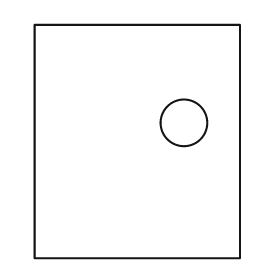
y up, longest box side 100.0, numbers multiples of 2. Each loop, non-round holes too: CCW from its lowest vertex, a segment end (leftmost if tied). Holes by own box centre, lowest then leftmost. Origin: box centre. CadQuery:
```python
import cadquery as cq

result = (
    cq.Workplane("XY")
    .moveTo(-44.0, -50.0)
    .lineTo(44.0, -50.0)
    .lineTo(44.0, 50.0)
    .lineTo(-44.0, 50.0)
    .close()
    .moveTo(20.0, 8.0)
    .circle(10.0)
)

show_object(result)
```